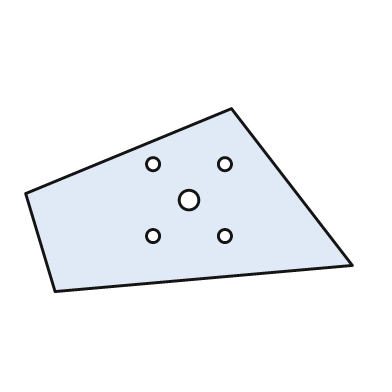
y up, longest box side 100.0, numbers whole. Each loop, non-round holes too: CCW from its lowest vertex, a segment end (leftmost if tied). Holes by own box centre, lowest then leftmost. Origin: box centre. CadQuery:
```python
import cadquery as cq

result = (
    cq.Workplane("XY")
    .moveTo(-41.0, -28.0)
    .lineTo(50.0, -20.0)
    .lineTo(13.0, 28.0)
    .lineTo(-50.0, 2.0)
    .close()
    .moveTo(-11.0, -11.0)
    .circle(2.0)
    .moveTo(11.0, -11.0)
    .circle(2.0)
    .moveTo(0.0, 0.0)
    .circle(3.0)
    .moveTo(-11.0, 11.0)
    .circle(2.0)
    .moveTo(11.0, 11.0)
    .circle(2.0)
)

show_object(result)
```